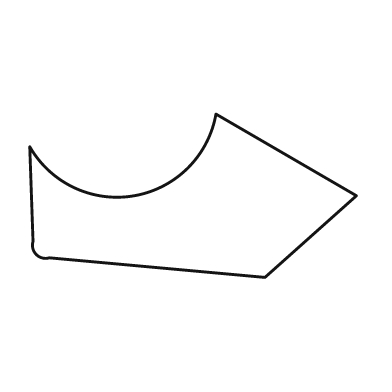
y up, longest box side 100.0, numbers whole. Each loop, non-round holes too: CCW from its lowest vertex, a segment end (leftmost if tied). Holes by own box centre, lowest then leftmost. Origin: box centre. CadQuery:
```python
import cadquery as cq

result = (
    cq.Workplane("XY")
    .moveTo(22.0, -25.0)
    .lineTo(50.0, 0.0)
    .lineTo(7.0, 25.0)
    .threePointArc((-18.0, 0.0), (-50.0, 15.0))
    .lineTo(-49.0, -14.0)
    .threePointArc((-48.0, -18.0), (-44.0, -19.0))
    .close()
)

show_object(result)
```